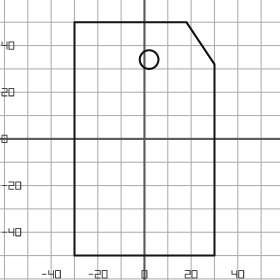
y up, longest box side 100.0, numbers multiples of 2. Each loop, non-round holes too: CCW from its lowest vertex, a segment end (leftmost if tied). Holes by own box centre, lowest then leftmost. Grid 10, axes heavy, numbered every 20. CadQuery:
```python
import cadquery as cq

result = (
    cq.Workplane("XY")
    .moveTo(-30.0, -50.0)
    .lineTo(30.0, -50.0)
    .lineTo(30.0, 32.0)
    .lineTo(18.0, 50.0)
    .lineTo(-30.0, 50.0)
    .close()
    .moveTo(2.0, 34.0)
    .circle(4.0)
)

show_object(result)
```